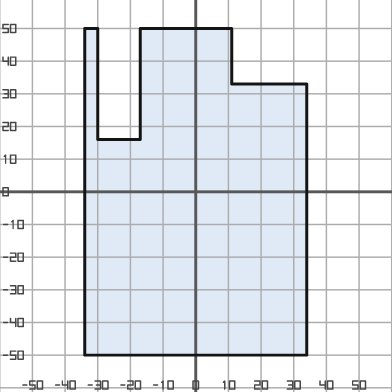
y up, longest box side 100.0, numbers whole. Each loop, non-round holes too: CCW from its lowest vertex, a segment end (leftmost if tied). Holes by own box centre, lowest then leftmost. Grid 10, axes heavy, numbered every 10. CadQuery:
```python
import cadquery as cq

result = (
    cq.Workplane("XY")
    .moveTo(-34.0, -50.0)
    .lineTo(34.0, -50.0)
    .lineTo(34.0, 33.0)
    .lineTo(11.0, 33.0)
    .lineTo(11.0, 50.0)
    .lineTo(-17.0, 50.0)
    .lineTo(-17.0, 16.0)
    .lineTo(-30.0, 16.0)
    .lineTo(-30.0, 50.0)
    .lineTo(-34.0, 50.0)
    .close()
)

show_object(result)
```